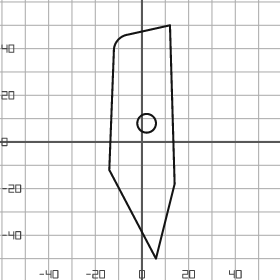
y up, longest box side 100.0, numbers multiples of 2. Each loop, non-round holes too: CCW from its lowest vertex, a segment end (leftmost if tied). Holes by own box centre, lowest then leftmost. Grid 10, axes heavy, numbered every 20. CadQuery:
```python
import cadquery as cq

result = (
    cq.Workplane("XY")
    .moveTo(6.0, -50.0)
    .lineTo(14.0, -18.0)
    .lineTo(12.0, 50.0)
    .lineTo(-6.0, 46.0)
    .threePointArc((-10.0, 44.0), (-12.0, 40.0))
    .lineTo(-14.0, -12.0)
    .close()
    .moveTo(2.0, 8.0)
    .circle(4.0)
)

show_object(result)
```